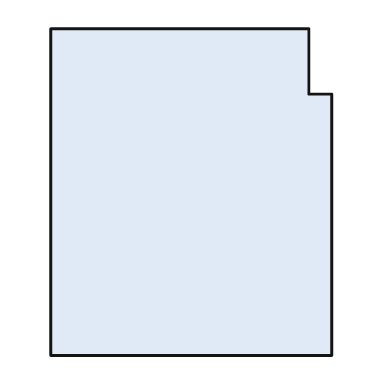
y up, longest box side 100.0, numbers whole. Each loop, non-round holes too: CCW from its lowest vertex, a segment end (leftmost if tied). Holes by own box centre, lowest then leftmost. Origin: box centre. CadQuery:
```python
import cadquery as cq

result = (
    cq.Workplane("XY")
    .moveTo(-43.0, -50.0)
    .lineTo(43.0, -50.0)
    .lineTo(43.0, 30.0)
    .lineTo(36.0, 30.0)
    .lineTo(36.0, 50.0)
    .lineTo(-43.0, 50.0)
    .close()
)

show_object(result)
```